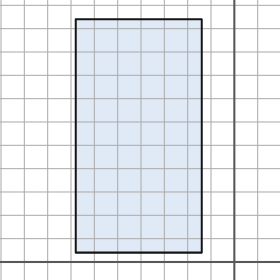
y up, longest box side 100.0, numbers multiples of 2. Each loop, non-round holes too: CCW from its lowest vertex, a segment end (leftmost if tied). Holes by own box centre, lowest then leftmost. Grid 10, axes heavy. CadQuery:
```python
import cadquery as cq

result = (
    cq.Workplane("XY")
    .moveTo(-68.0, 4.0)
    .lineTo(-14.0, 4.0)
    .lineTo(-14.0, 104.0)
    .lineTo(-68.0, 104.0)
    .close()
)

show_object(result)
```